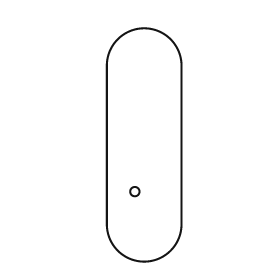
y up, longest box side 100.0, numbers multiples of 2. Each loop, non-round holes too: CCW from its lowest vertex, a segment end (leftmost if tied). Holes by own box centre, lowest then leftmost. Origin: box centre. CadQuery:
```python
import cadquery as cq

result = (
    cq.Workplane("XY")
    .moveTo(-16.0, -34.0)
    .threePointArc((0.0, -50.0), (16.0, -34.0))
    .lineTo(16.0, 34.0)
    .threePointArc((0.0, 50.0), (-16.0, 34.0))
    .close()
    .moveTo(-4.0, -20.0)
    .circle(2.0)
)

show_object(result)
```